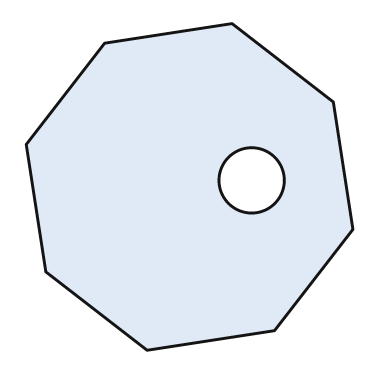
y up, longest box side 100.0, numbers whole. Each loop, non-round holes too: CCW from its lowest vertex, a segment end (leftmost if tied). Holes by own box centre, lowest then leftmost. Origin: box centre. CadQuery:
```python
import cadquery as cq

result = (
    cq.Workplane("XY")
    .moveTo(-13.0, -50.0)
    .lineTo(26.0, -44.0)
    .lineTo(50.0, -13.0)
    .lineTo(44.0, 26.0)
    .lineTo(13.0, 50.0)
    .lineTo(-26.0, 44.0)
    .lineTo(-50.0, 13.0)
    .lineTo(-44.0, -26.0)
    .close()
    .moveTo(19.0, 2.0)
    .circle(10.0)
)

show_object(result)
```